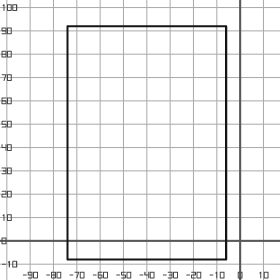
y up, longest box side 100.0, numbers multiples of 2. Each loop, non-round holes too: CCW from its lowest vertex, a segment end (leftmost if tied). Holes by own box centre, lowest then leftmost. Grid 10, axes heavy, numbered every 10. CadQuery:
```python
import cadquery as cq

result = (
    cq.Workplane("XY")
    .moveTo(-74.0, -8.0)
    .lineTo(-6.0, -8.0)
    .lineTo(-6.0, 92.0)
    .lineTo(-74.0, 92.0)
    .close()
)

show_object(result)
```